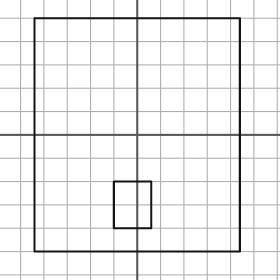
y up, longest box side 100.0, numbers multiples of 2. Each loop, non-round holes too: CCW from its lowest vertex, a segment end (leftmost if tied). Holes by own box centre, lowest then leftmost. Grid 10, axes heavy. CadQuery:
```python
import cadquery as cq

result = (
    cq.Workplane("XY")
    .moveTo(-44.0, -50.0)
    .lineTo(44.0, -50.0)
    .lineTo(44.0, 50.0)
    .lineTo(-44.0, 50.0)
    .close()
    .moveTo(-10.0, -40.0)
    .lineTo(6.0, -40.0)
    .lineTo(6.0, -20.0)
    .lineTo(-10.0, -20.0)
    .close()
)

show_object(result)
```